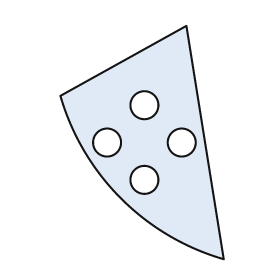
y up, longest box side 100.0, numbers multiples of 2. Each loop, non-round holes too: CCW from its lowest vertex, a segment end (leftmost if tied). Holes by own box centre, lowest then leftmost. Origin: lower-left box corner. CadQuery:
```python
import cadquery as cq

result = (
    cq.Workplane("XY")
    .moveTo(70.0, 0.0)
    .lineTo(54.0, 100.0)
    .lineTo(0.0, 70.0)
    .threePointArc((26.0, 26.0), (70.0, 0.0))
    .close()
    .moveTo(36.0, 34.0)
    .circle(6.0)
    .moveTo(20.0, 50.0)
    .circle(6.0)
    .moveTo(52.0, 50.0)
    .circle(6.0)
    .moveTo(36.0, 66.0)
    .circle(6.0)
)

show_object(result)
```